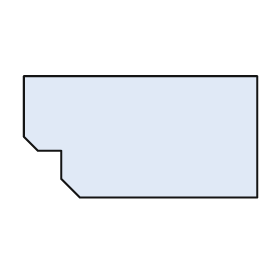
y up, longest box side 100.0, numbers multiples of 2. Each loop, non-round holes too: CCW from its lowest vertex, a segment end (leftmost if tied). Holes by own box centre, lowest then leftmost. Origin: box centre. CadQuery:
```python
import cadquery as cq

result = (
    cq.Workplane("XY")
    .moveTo(-26.0, -26.0)
    .lineTo(50.0, -26.0)
    .lineTo(50.0, 26.0)
    .lineTo(-50.0, 26.0)
    .lineTo(-50.0, 0.0)
    .lineTo(-44.0, -6.0)
    .lineTo(-34.0, -6.0)
    .lineTo(-34.0, -18.0)
    .close()
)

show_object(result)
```